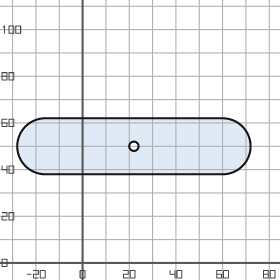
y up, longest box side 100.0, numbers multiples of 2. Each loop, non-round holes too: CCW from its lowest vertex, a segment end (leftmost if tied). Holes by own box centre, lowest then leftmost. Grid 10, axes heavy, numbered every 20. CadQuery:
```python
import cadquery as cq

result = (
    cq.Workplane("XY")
    .moveTo(-16.0, 38.0)
    .lineTo(60.0, 38.0)
    .threePointArc((72.0, 50.0), (60.0, 62.0))
    .lineTo(-16.0, 62.0)
    .threePointArc((-28.0, 50.0), (-16.0, 38.0))
    .close()
    .moveTo(22.0, 50.0)
    .circle(2.0)
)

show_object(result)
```